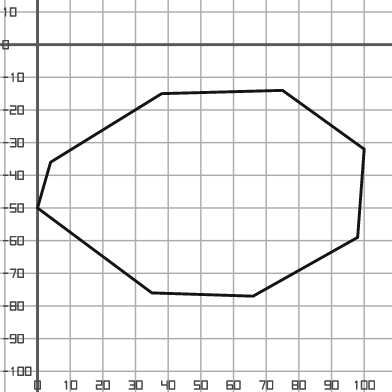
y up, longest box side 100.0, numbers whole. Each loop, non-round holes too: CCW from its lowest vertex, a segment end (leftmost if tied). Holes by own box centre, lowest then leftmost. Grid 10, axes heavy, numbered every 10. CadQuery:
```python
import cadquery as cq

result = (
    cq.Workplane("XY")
    .moveTo(66.0, -77.0)
    .lineTo(98.0, -59.0)
    .lineTo(100.0, -32.0)
    .lineTo(75.0, -14.0)
    .lineTo(38.0, -15.0)
    .lineTo(4.0, -36.0)
    .lineTo(0.0, -50.0)
    .lineTo(35.0, -76.0)
    .close()
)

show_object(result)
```